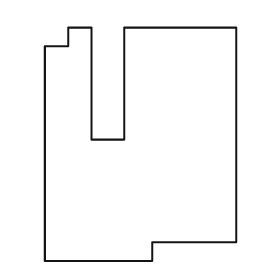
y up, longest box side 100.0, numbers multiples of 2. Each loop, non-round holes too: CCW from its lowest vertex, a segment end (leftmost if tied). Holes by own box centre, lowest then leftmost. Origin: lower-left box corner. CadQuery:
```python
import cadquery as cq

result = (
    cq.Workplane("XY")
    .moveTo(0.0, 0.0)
    .lineTo(46.0, 0.0)
    .lineTo(46.0, 8.0)
    .lineTo(82.0, 8.0)
    .lineTo(82.0, 100.0)
    .lineTo(34.0, 100.0)
    .lineTo(34.0, 52.0)
    .lineTo(20.0, 52.0)
    .lineTo(20.0, 100.0)
    .lineTo(10.0, 100.0)
    .lineTo(10.0, 92.0)
    .lineTo(0.0, 92.0)
    .close()
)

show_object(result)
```